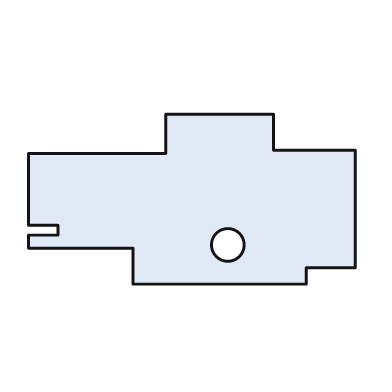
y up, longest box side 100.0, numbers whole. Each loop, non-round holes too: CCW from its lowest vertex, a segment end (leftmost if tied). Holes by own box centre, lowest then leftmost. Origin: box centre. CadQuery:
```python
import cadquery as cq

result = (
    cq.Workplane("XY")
    .moveTo(-18.0, -26.0)
    .lineTo(35.0, -26.0)
    .lineTo(35.0, -21.0)
    .lineTo(50.0, -21.0)
    .lineTo(50.0, 15.0)
    .lineTo(25.0, 15.0)
    .lineTo(25.0, 26.0)
    .lineTo(-8.0, 26.0)
    .lineTo(-8.0, 14.0)
    .lineTo(-50.0, 14.0)
    .lineTo(-50.0, -8.0)
    .lineTo(-41.0, -8.0)
    .lineTo(-41.0, -11.0)
    .lineTo(-50.0, -11.0)
    .lineTo(-50.0, -15.0)
    .lineTo(-18.0, -15.0)
    .close()
    .moveTo(11.0, -14.0)
    .circle(5.0)
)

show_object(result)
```